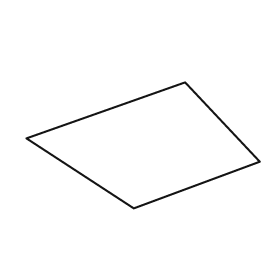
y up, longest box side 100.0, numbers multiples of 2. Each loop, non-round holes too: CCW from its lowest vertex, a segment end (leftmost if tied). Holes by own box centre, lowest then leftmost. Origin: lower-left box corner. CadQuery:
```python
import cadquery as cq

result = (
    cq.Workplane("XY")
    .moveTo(46.0, 0.0)
    .lineTo(100.0, 20.0)
    .lineTo(68.0, 54.0)
    .lineTo(0.0, 30.0)
    .close()
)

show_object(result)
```